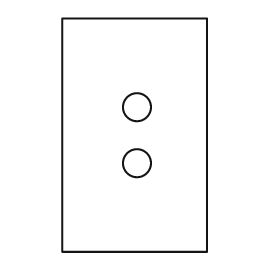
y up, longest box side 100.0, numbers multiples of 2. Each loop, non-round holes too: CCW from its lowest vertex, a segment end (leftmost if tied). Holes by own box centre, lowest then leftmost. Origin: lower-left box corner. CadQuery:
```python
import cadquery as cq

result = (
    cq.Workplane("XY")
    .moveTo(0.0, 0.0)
    .lineTo(62.0, 0.0)
    .lineTo(62.0, 100.0)
    .lineTo(0.0, 100.0)
    .close()
    .moveTo(32.0, 38.0)
    .circle(6.0)
    .moveTo(32.0, 62.0)
    .circle(6.0)
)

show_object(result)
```